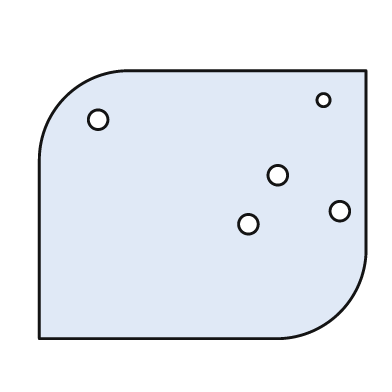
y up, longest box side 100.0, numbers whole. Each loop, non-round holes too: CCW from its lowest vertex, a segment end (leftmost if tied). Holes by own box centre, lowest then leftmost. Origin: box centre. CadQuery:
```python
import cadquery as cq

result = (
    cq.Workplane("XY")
    .moveTo(-50.0, -41.0)
    .lineTo(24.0, -41.0)
    .threePointArc((42.0, -33.0), (50.0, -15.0))
    .lineTo(50.0, 41.0)
    .lineTo(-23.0, 41.0)
    .threePointArc((-42.0, 33.0), (-50.0, 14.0))
    .close()
    .moveTo(14.0, -6.0)
    .circle(3.0)
    .moveTo(42.0, -2.0)
    .circle(3.0)
    .moveTo(23.0, 9.0)
    .circle(3.0)
    .moveTo(-32.0, 26.0)
    .circle(3.0)
    .moveTo(37.0, 32.0)
    .circle(2.0)
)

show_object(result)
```